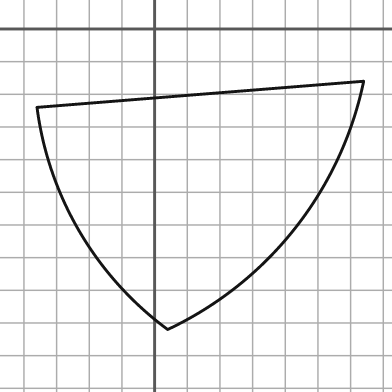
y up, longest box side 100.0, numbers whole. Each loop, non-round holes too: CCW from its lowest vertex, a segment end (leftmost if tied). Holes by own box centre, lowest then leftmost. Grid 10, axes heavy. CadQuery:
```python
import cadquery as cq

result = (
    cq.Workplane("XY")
    .moveTo(4.0, -92.0)
    .threePointArc((43.0, -61.0), (64.0, -16.0))
    .lineTo(-36.0, -24.0)
    .threePointArc((-23.0, -62.0), (4.0, -92.0))
    .close()
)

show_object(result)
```